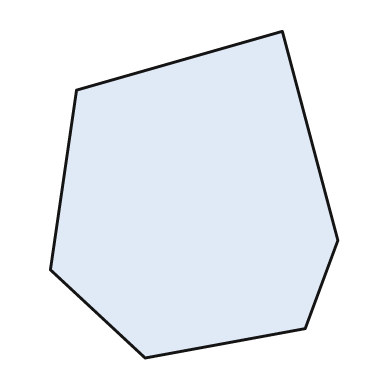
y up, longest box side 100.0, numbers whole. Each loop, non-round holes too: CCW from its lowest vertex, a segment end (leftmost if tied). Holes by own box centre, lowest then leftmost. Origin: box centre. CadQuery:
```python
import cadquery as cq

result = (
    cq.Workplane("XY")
    .moveTo(-15.0, -50.0)
    .lineTo(34.0, -41.0)
    .lineTo(44.0, -14.0)
    .lineTo(27.0, 50.0)
    .lineTo(-36.0, 32.0)
    .lineTo(-44.0, -23.0)
    .close()
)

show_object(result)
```